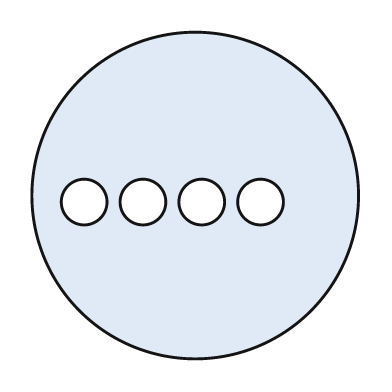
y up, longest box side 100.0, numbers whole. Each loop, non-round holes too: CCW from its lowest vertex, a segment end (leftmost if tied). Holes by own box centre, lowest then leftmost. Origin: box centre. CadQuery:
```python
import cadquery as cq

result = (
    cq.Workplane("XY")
    .moveTo(0.0, 0.0)
    .circle(50.0)
    .moveTo(-34.0, -2.0)
    .circle(7.0)
    .moveTo(-16.0, -2.0)
    .circle(7.0)
    .moveTo(2.0, -2.0)
    .circle(7.0)
    .moveTo(20.0, -2.0)
    .circle(7.0)
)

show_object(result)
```